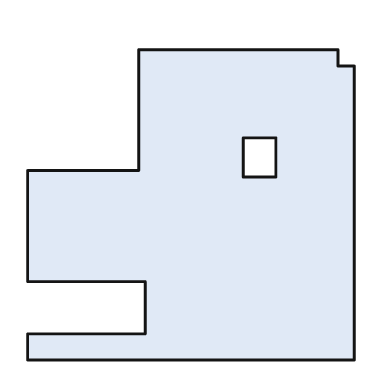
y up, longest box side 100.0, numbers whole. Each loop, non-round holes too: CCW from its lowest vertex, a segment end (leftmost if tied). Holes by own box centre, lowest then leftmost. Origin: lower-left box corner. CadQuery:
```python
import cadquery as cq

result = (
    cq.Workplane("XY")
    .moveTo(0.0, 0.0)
    .lineTo(100.0, 0.0)
    .lineTo(100.0, 90.0)
    .lineTo(95.0, 90.0)
    .lineTo(95.0, 95.0)
    .lineTo(34.0, 95.0)
    .lineTo(34.0, 58.0)
    .lineTo(0.0, 58.0)
    .lineTo(0.0, 24.0)
    .lineTo(36.0, 24.0)
    .lineTo(36.0, 8.0)
    .lineTo(0.0, 8.0)
    .close()
    .moveTo(66.0, 56.0)
    .lineTo(76.0, 56.0)
    .lineTo(76.0, 68.0)
    .lineTo(66.0, 68.0)
    .close()
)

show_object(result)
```